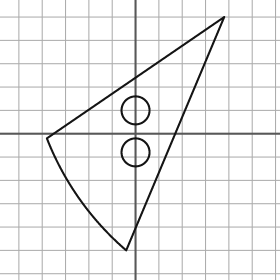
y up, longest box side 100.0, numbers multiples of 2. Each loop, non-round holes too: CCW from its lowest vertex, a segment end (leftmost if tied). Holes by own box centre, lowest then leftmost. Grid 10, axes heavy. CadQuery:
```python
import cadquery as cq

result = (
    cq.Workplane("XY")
    .moveTo(-4.0, -50.0)
    .lineTo(38.0, 50.0)
    .lineTo(-38.0, -2.0)
    .threePointArc((-24.0, -28.0), (-4.0, -50.0))
    .close()
    .moveTo(0.0, -8.0)
    .circle(6.0)
    .moveTo(0.0, 10.0)
    .circle(6.0)
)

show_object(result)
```